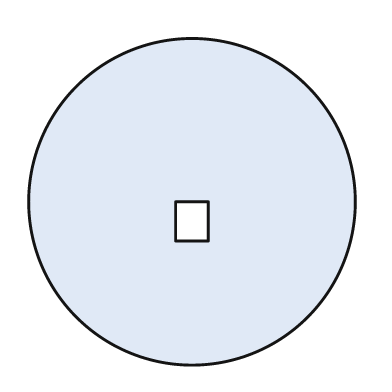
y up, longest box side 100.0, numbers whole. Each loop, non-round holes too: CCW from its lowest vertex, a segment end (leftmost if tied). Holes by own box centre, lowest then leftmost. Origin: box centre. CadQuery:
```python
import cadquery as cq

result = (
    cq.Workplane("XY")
    .moveTo(0.0, 0.0)
    .circle(50.0)
    .moveTo(-5.0, -12.0)
    .lineTo(5.0, -12.0)
    .lineTo(5.0, 0.0)
    .lineTo(-5.0, 0.0)
    .close()
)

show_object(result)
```